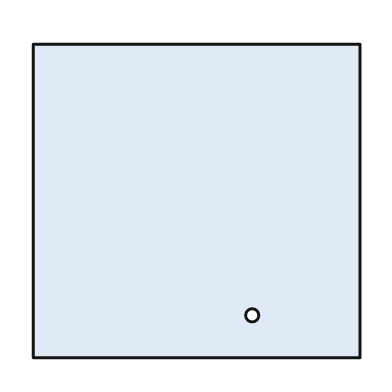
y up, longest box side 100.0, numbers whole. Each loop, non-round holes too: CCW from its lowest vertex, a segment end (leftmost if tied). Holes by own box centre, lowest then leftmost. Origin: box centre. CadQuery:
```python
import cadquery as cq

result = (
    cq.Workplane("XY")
    .moveTo(-50.0, -48.0)
    .lineTo(50.0, -48.0)
    .lineTo(50.0, 48.0)
    .lineTo(-50.0, 48.0)
    .close()
    .moveTo(17.0, -35.0)
    .circle(2.0)
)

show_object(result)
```